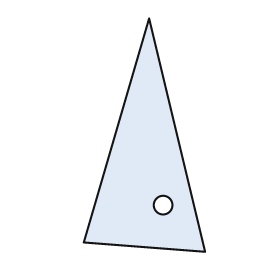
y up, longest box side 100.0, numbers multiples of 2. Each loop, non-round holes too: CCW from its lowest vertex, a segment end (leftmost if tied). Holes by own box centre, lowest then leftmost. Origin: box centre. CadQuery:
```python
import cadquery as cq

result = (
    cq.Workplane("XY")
    .moveTo(26.0, -50.0)
    .lineTo(2.0, 50.0)
    .lineTo(-26.0, -46.0)
    .close()
    .moveTo(8.0, -30.0)
    .circle(4.0)
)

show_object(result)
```